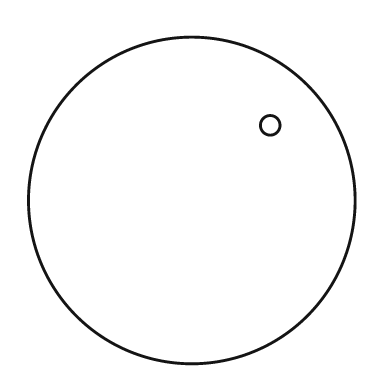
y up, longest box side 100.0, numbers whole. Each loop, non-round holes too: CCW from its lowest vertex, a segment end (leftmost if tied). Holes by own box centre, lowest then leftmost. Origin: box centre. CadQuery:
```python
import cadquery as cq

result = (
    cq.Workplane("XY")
    .moveTo(0.0, 0.0)
    .circle(50.0)
    .moveTo(24.0, 23.0)
    .circle(3.0)
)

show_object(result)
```